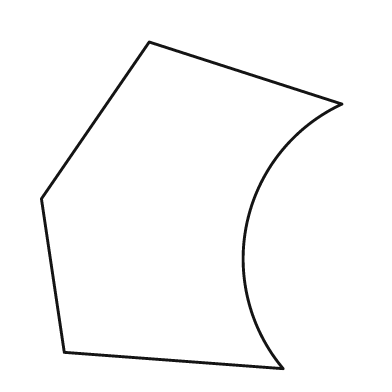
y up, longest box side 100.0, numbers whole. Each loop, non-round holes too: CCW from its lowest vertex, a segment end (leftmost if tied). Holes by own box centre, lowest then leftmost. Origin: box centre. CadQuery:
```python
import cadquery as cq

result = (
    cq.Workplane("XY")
    .moveTo(28.0, -50.0)
    .threePointArc((17.0, -5.0), (46.0, 31.0))
    .lineTo(-13.0, 50.0)
    .lineTo(-46.0, 2.0)
    .lineTo(-39.0, -45.0)
    .close()
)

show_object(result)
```